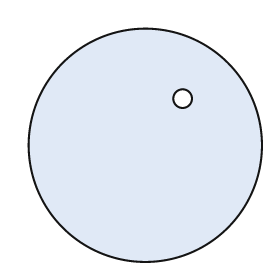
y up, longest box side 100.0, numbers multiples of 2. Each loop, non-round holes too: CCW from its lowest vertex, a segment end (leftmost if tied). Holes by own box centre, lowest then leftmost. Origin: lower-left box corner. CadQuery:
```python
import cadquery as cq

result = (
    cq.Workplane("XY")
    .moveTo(50.0, 50.0)
    .circle(50.0)
    .moveTo(66.0, 70.0)
    .circle(4.0)
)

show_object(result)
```